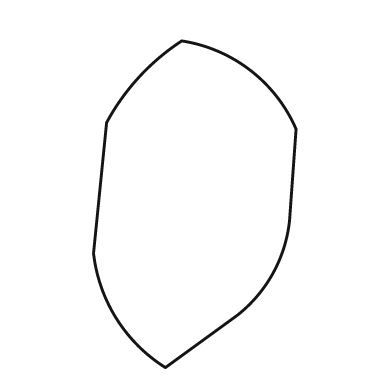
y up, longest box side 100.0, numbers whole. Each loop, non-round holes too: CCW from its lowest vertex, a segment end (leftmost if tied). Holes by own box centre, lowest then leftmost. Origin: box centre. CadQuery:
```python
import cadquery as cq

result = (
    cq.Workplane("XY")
    .moveTo(-9.0, -50.0)
    .lineTo(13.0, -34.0)
    .threePointArc((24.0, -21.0), (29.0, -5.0))
    .lineTo(31.0, 23.0)
    .threePointArc((17.0, 41.0), (-4.0, 50.0))
    .threePointArc((-17.0, 39.0), (-27.0, 25.0))
    .lineTo(-31.0, -15.0)
    .threePointArc((-24.0, -35.0), (-9.0, -50.0))
    .close()
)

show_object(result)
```